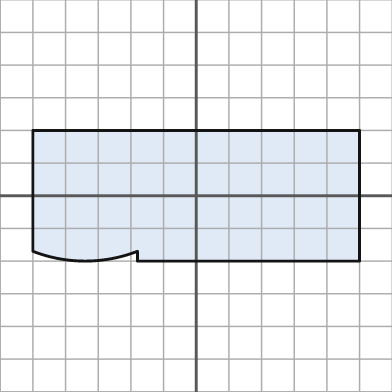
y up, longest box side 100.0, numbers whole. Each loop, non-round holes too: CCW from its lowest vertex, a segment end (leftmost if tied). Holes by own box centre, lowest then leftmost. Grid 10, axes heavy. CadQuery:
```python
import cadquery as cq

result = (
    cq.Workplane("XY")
    .moveTo(-18.0, -20.0)
    .lineTo(50.0, -20.0)
    .lineTo(50.0, 20.0)
    .lineTo(-50.0, 20.0)
    .lineTo(-50.0, -17.0)
    .threePointArc((-34.0, -20.0), (-18.0, -17.0))
    .close()
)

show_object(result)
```